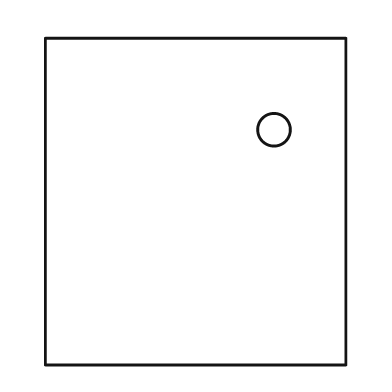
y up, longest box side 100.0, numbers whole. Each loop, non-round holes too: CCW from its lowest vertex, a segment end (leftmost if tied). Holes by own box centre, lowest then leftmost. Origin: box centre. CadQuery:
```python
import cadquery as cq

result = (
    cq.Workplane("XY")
    .moveTo(-46.0, -50.0)
    .lineTo(46.0, -50.0)
    .lineTo(46.0, 50.0)
    .lineTo(-46.0, 50.0)
    .close()
    .moveTo(24.0, 22.0)
    .circle(5.0)
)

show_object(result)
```